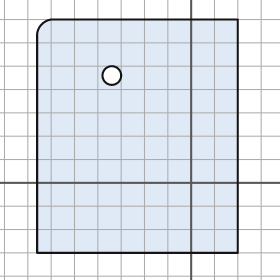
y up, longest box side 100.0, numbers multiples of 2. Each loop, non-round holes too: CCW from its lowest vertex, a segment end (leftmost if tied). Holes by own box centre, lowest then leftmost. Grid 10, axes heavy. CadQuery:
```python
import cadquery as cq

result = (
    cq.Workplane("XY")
    .moveTo(-66.0, -30.0)
    .lineTo(20.0, -30.0)
    .lineTo(20.0, 70.0)
    .lineTo(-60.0, 70.0)
    .threePointArc((-64.0, 68.0), (-66.0, 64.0))
    .close()
    .moveTo(-34.0, 46.0)
    .circle(4.0)
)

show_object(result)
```